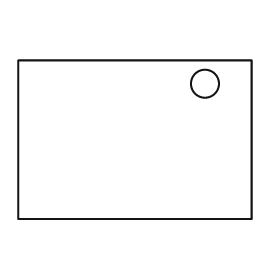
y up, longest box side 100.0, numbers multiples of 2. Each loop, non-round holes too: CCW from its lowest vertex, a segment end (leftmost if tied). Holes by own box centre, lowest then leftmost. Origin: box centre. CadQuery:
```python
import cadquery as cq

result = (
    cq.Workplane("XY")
    .moveTo(-50.0, -34.0)
    .lineTo(50.0, -34.0)
    .lineTo(50.0, 34.0)
    .lineTo(-50.0, 34.0)
    .close()
    .moveTo(30.0, 24.0)
    .circle(6.0)
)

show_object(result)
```